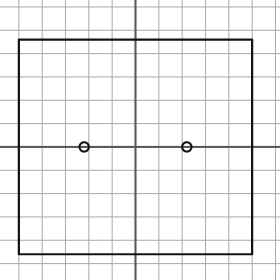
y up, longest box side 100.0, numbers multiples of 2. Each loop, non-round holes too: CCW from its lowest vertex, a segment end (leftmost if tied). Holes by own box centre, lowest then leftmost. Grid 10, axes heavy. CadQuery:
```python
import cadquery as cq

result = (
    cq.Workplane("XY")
    .moveTo(-50.0, -46.0)
    .lineTo(50.0, -46.0)
    .lineTo(50.0, 46.0)
    .lineTo(-50.0, 46.0)
    .close()
    .moveTo(-22.0, 0.0)
    .circle(2.0)
    .moveTo(22.0, 0.0)
    .circle(2.0)
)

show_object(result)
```